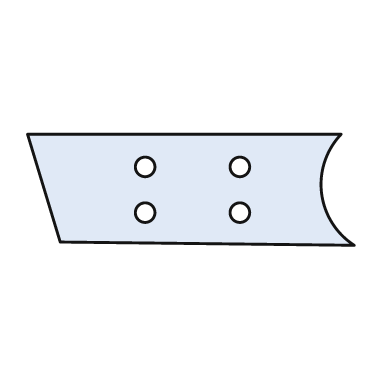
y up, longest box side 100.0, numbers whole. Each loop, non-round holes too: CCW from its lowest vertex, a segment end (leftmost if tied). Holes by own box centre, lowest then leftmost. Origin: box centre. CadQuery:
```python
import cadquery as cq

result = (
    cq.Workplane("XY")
    .moveTo(50.0, -17.0)
    .threePointArc((40.0, -1.0), (46.0, 17.0))
    .lineTo(-50.0, 17.0)
    .lineTo(-40.0, -16.0)
    .close()
    .moveTo(-14.0, -7.0)
    .circle(3.0)
    .moveTo(15.0, -7.0)
    .circle(3.0)
    .moveTo(-14.0, 7.0)
    .circle(3.0)
    .moveTo(15.0, 7.0)
    .circle(3.0)
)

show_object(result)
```